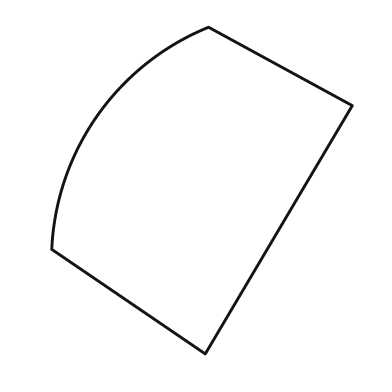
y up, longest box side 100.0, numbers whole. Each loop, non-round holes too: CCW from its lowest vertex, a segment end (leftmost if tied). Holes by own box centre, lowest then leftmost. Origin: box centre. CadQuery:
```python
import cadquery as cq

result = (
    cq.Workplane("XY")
    .moveTo(1.0, -50.0)
    .lineTo(46.0, 26.0)
    .lineTo(2.0, 50.0)
    .threePointArc((-32.0, 23.0), (-46.0, -18.0))
    .close()
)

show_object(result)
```